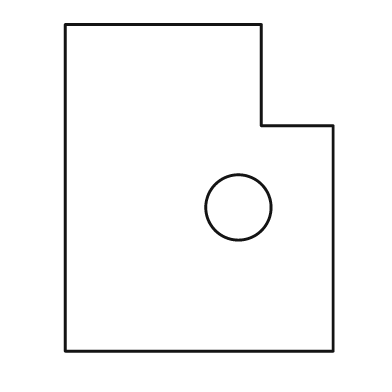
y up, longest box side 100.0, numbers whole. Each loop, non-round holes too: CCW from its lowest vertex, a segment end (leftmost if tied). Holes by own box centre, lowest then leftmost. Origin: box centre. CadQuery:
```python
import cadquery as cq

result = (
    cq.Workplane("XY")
    .moveTo(-41.0, -50.0)
    .lineTo(41.0, -50.0)
    .lineTo(41.0, 19.0)
    .lineTo(19.0, 19.0)
    .lineTo(19.0, 50.0)
    .lineTo(-41.0, 50.0)
    .close()
    .moveTo(12.0, -6.0)
    .circle(10.0)
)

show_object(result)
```